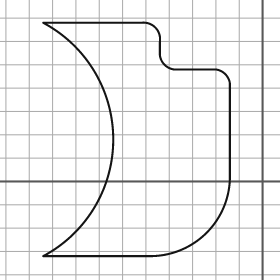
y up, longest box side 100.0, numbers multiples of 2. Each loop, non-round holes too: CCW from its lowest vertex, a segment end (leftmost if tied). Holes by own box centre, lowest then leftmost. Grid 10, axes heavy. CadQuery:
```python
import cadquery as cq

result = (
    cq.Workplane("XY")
    .moveTo(-94.0, -32.0)
    .lineTo(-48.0, -32.0)
    .threePointArc((-24.0, -22.0), (-14.0, 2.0))
    .lineTo(-14.0, 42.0)
    .threePointArc((-16.0, 46.0), (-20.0, 48.0))
    .lineTo(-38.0, 48.0)
    .threePointArc((-42.0, 50.0), (-44.0, 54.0))
    .lineTo(-44.0, 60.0)
    .threePointArc((-46.0, 66.0), (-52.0, 68.0))
    .lineTo(-94.0, 68.0)
    .threePointArc((-64.0, 18.0), (-94.0, -32.0))
    .close()
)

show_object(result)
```